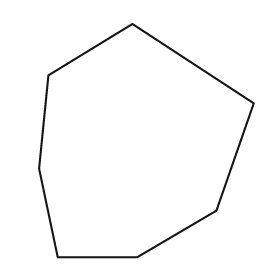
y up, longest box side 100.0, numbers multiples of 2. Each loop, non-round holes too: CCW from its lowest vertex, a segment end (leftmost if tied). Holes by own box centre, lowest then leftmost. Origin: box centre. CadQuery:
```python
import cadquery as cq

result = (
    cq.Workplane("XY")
    .moveTo(-38.0, -50.0)
    .lineTo(-4.0, -50.0)
    .lineTo(30.0, -30.0)
    .lineTo(46.0, 16.0)
    .lineTo(-6.0, 50.0)
    .lineTo(-42.0, 28.0)
    .lineTo(-46.0, -12.0)
    .close()
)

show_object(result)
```